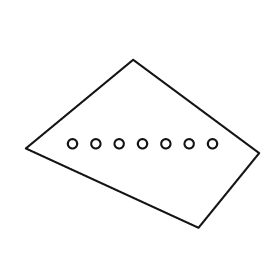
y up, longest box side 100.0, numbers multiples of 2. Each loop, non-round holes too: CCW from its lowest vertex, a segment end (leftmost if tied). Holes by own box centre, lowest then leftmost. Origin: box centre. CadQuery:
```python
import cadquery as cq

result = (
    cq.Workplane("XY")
    .moveTo(24.0, -36.0)
    .lineTo(50.0, -4.0)
    .lineTo(-4.0, 36.0)
    .lineTo(-50.0, -2.0)
    .close()
    .moveTo(-30.0, 0.0)
    .circle(2.0)
    .moveTo(-20.0, 0.0)
    .circle(2.0)
    .moveTo(-10.0, 0.0)
    .circle(2.0)
    .moveTo(0.0, 0.0)
    .circle(2.0)
    .moveTo(10.0, 0.0)
    .circle(2.0)
    .moveTo(20.0, 0.0)
    .circle(2.0)
    .moveTo(30.0, 0.0)
    .circle(2.0)
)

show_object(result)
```